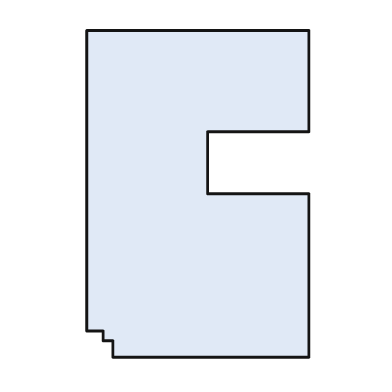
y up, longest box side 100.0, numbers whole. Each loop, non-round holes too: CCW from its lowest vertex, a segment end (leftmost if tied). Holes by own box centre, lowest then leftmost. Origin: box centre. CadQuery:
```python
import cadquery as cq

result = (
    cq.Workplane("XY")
    .moveTo(-26.0, -50.0)
    .lineTo(34.0, -50.0)
    .lineTo(34.0, 0.0)
    .lineTo(3.0, 0.0)
    .lineTo(3.0, 19.0)
    .lineTo(34.0, 19.0)
    .lineTo(34.0, 50.0)
    .lineTo(-34.0, 50.0)
    .lineTo(-34.0, -42.0)
    .lineTo(-29.0, -42.0)
    .lineTo(-29.0, -45.0)
    .lineTo(-26.0, -45.0)
    .close()
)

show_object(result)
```